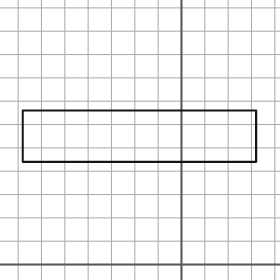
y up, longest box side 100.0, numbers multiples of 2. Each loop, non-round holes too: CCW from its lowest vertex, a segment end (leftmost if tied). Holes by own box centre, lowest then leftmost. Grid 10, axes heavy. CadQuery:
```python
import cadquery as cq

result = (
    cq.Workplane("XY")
    .moveTo(-68.0, 44.0)
    .lineTo(32.0, 44.0)
    .lineTo(32.0, 66.0)
    .lineTo(-68.0, 66.0)
    .close()
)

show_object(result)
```